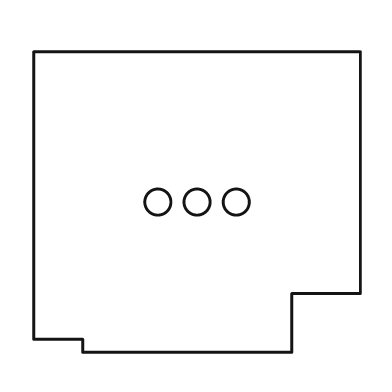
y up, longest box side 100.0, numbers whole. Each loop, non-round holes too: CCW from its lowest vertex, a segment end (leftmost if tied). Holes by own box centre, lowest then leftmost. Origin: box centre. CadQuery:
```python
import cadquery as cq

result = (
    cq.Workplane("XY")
    .moveTo(-35.0, -46.0)
    .lineTo(29.0, -46.0)
    .lineTo(29.0, -28.0)
    .lineTo(50.0, -28.0)
    .lineTo(50.0, 46.0)
    .lineTo(-50.0, 46.0)
    .lineTo(-50.0, -42.0)
    .lineTo(-35.0, -42.0)
    .close()
    .moveTo(-12.0, 0.0)
    .circle(4.0)
    .moveTo(0.0, 0.0)
    .circle(4.0)
    .moveTo(12.0, 0.0)
    .circle(4.0)
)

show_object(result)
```